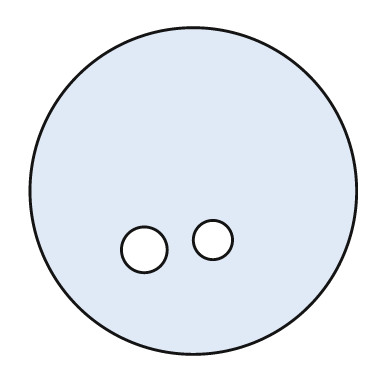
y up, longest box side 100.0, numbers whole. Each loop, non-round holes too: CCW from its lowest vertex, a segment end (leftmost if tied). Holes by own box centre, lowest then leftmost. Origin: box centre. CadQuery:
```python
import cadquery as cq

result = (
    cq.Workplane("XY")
    .moveTo(0.0, 0.0)
    .circle(50.0)
    .moveTo(-15.0, -18.0)
    .circle(7.0)
    .moveTo(6.0, -15.0)
    .circle(6.0)
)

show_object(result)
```